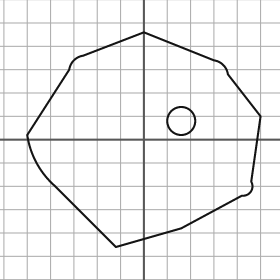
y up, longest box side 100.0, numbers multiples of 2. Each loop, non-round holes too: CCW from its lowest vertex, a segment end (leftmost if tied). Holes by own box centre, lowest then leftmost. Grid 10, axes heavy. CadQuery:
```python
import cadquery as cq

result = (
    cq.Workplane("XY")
    .moveTo(-12.0, -46.0)
    .lineTo(16.0, -38.0)
    .lineTo(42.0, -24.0)
    .threePointArc((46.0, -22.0), (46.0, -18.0))
    .lineTo(50.0, 10.0)
    .lineTo(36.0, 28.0)
    .threePointArc((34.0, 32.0), (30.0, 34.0))
    .lineTo(0.0, 46.0)
    .lineTo(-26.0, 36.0)
    .threePointArc((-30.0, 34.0), (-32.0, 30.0))
    .lineTo(-50.0, 2.0)
    .threePointArc((-46.0, -10.0), (-38.0, -20.0))
    .close()
    .moveTo(16.0, 8.0)
    .circle(6.0)
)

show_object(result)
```